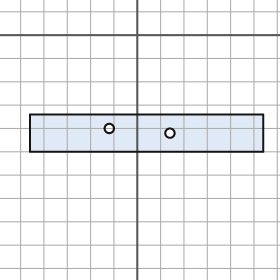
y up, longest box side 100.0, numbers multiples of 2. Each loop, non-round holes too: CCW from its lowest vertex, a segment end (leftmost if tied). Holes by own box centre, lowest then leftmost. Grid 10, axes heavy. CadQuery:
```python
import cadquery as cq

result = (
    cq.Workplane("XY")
    .moveTo(-46.0, -50.0)
    .lineTo(54.0, -50.0)
    .lineTo(54.0, -34.0)
    .lineTo(-46.0, -34.0)
    .close()
    .moveTo(14.0, -42.0)
    .circle(2.0)
    .moveTo(-12.0, -40.0)
    .circle(2.0)
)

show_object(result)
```